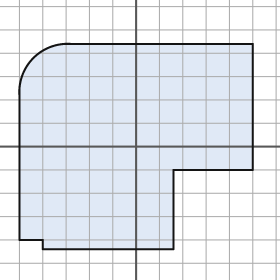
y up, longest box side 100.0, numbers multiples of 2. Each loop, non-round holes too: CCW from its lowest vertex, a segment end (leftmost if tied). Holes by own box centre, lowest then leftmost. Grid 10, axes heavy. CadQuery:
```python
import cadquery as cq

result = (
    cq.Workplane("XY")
    .moveTo(-40.0, -44.0)
    .lineTo(16.0, -44.0)
    .lineTo(16.0, -10.0)
    .lineTo(50.0, -10.0)
    .lineTo(50.0, 44.0)
    .lineTo(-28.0, 44.0)
    .threePointArc((-44.0, 38.0), (-50.0, 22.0))
    .lineTo(-50.0, -40.0)
    .lineTo(-40.0, -40.0)
    .close()
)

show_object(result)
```